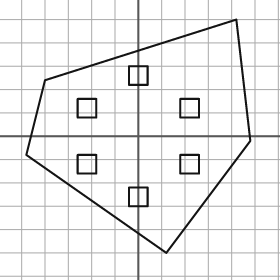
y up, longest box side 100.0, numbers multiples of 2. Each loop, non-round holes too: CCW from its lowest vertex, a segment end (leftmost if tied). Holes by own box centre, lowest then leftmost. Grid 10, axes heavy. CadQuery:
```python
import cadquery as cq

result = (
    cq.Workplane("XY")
    .moveTo(12.0, -50.0)
    .lineTo(48.0, -2.0)
    .lineTo(42.0, 50.0)
    .lineTo(-40.0, 24.0)
    .lineTo(-48.0, -8.0)
    .close()
    .moveTo(-4.0, -30.0)
    .lineTo(4.0, -30.0)
    .lineTo(4.0, -22.0)
    .lineTo(-4.0, -22.0)
    .close()
    .moveTo(-26.0, -16.0)
    .lineTo(-18.0, -16.0)
    .lineTo(-18.0, -8.0)
    .lineTo(-26.0, -8.0)
    .close()
    .moveTo(18.0, -16.0)
    .lineTo(26.0, -16.0)
    .lineTo(26.0, -8.0)
    .lineTo(18.0, -8.0)
    .close()
    .moveTo(-26.0, 8.0)
    .lineTo(-18.0, 8.0)
    .lineTo(-18.0, 16.0)
    .lineTo(-26.0, 16.0)
    .close()
    .moveTo(18.0, 8.0)
    .lineTo(26.0, 8.0)
    .lineTo(26.0, 16.0)
    .lineTo(18.0, 16.0)
    .close()
    .moveTo(-4.0, 22.0)
    .lineTo(4.0, 22.0)
    .lineTo(4.0, 30.0)
    .lineTo(-4.0, 30.0)
    .close()
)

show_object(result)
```